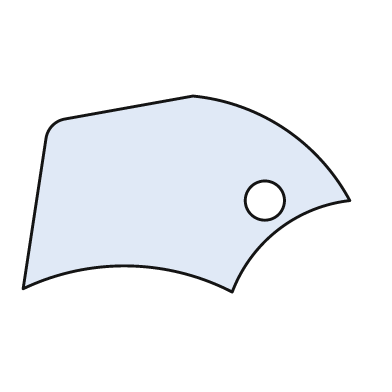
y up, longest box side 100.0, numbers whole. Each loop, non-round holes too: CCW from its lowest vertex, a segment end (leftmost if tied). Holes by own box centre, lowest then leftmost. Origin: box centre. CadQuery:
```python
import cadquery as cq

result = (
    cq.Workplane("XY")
    .moveTo(14.0, -30.0)
    .threePointArc((28.0, -11.0), (50.0, -2.0))
    .threePointArc((30.0, 20.0), (2.0, 30.0))
    .lineTo(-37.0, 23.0)
    .threePointArc((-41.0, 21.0), (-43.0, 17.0))
    .lineTo(-50.0, -29.0)
    .threePointArc((-18.0, -22.0), (14.0, -30.0))
    .close()
    .moveTo(24.0, -2.0)
    .circle(6.0)
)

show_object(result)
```